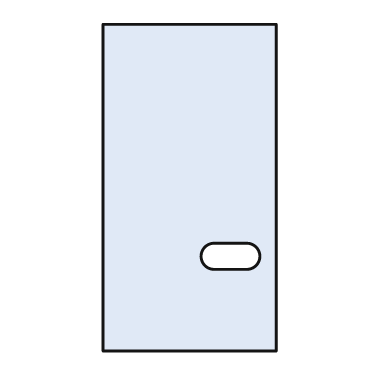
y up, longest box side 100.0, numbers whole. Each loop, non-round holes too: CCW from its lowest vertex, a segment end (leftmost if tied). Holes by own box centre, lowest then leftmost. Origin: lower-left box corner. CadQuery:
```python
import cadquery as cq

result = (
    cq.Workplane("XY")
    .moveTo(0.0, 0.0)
    .lineTo(53.0, 0.0)
    .lineTo(53.0, 100.0)
    .lineTo(0.0, 100.0)
    .close()
    .moveTo(34.0, 25.0)
    .lineTo(44.0, 25.0)
    .threePointArc((48.0, 29.0), (44.0, 33.0))
    .lineTo(34.0, 33.0)
    .threePointArc((30.0, 29.0), (34.0, 25.0))
    .close()
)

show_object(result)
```